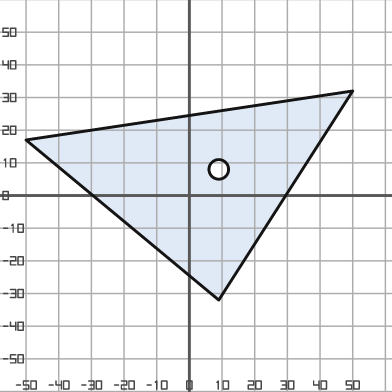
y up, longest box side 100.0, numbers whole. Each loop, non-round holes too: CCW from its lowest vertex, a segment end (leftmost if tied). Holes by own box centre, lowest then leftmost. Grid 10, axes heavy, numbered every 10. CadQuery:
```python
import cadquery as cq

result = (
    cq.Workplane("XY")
    .moveTo(9.0, -32.0)
    .lineTo(50.0, 32.0)
    .lineTo(-50.0, 17.0)
    .close()
    .moveTo(9.0, 8.0)
    .circle(3.0)
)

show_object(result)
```